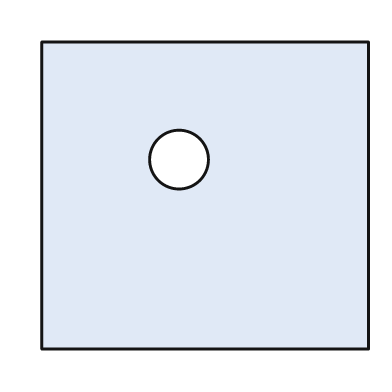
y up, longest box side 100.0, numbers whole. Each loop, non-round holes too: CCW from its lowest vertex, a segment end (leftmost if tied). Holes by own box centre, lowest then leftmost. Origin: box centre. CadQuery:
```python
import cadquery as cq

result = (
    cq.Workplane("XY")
    .moveTo(-50.0, -47.0)
    .lineTo(50.0, -47.0)
    .lineTo(50.0, 47.0)
    .lineTo(-50.0, 47.0)
    .close()
    .moveTo(-8.0, 11.0)
    .circle(9.0)
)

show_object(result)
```